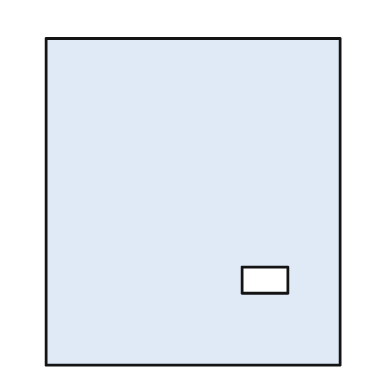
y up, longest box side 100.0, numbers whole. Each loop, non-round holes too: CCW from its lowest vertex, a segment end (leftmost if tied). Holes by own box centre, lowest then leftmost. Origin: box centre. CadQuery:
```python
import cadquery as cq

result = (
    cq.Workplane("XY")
    .moveTo(-45.0, -50.0)
    .lineTo(45.0, -50.0)
    .lineTo(45.0, 50.0)
    .lineTo(-45.0, 50.0)
    .close()
    .moveTo(15.0, -28.0)
    .lineTo(29.0, -28.0)
    .lineTo(29.0, -20.0)
    .lineTo(15.0, -20.0)
    .close()
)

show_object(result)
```